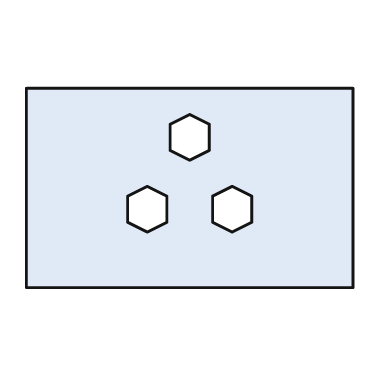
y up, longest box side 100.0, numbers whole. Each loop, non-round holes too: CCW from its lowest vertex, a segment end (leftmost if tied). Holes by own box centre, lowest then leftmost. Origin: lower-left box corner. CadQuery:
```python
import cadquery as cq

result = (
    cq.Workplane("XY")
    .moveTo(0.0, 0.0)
    .lineTo(100.0, 0.0)
    .lineTo(100.0, 61.0)
    .lineTo(0.0, 61.0)
    .close()
    .moveTo(37.0, 17.0)
    .lineTo(43.0, 20.0)
    .lineTo(43.0, 28.0)
    .lineTo(37.0, 31.0)
    .lineTo(31.0, 28.0)
    .lineTo(31.0, 20.0)
    .close()
    .moveTo(63.0, 17.0)
    .lineTo(69.0, 20.0)
    .lineTo(69.0, 28.0)
    .lineTo(63.0, 31.0)
    .lineTo(57.0, 28.0)
    .lineTo(57.0, 20.0)
    .close()
    .moveTo(50.0, 39.0)
    .lineTo(56.0, 42.0)
    .lineTo(56.0, 50.0)
    .lineTo(50.0, 53.0)
    .lineTo(44.0, 50.0)
    .lineTo(44.0, 42.0)
    .close()
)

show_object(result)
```